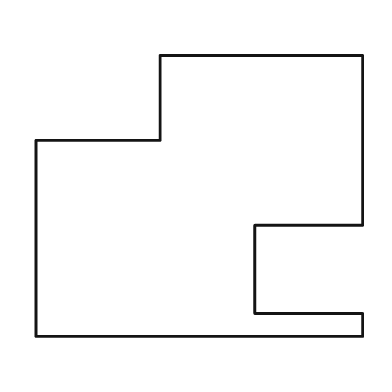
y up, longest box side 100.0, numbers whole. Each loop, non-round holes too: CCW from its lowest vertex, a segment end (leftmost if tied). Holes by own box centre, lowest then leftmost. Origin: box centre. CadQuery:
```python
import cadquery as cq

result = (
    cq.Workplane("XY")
    .moveTo(-50.0, -43.0)
    .lineTo(50.0, -43.0)
    .lineTo(50.0, -36.0)
    .lineTo(17.0, -36.0)
    .lineTo(17.0, -9.0)
    .lineTo(50.0, -9.0)
    .lineTo(50.0, 43.0)
    .lineTo(-12.0, 43.0)
    .lineTo(-12.0, 17.0)
    .lineTo(-50.0, 17.0)
    .close()
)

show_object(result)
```